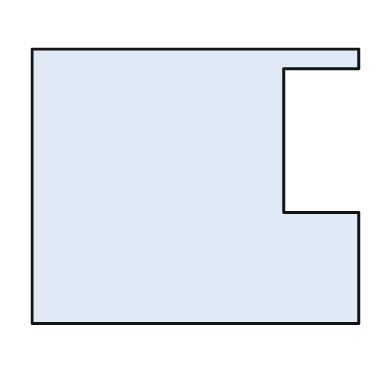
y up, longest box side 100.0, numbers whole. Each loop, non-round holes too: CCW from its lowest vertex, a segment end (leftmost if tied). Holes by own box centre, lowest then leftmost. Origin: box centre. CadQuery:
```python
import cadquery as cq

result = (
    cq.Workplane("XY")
    .moveTo(-50.0, -42.0)
    .lineTo(50.0, -42.0)
    .lineTo(50.0, -8.0)
    .lineTo(27.0, -8.0)
    .lineTo(27.0, 36.0)
    .lineTo(50.0, 36.0)
    .lineTo(50.0, 42.0)
    .lineTo(-50.0, 42.0)
    .close()
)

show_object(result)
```